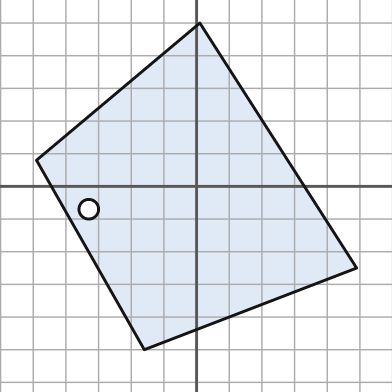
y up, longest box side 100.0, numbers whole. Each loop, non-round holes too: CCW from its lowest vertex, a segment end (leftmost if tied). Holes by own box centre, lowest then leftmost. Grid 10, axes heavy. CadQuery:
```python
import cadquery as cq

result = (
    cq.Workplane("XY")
    .moveTo(-16.0, -50.0)
    .lineTo(49.0, -25.0)
    .lineTo(1.0, 50.0)
    .lineTo(-49.0, 8.0)
    .close()
    .moveTo(-33.0, -7.0)
    .circle(3.0)
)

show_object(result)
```